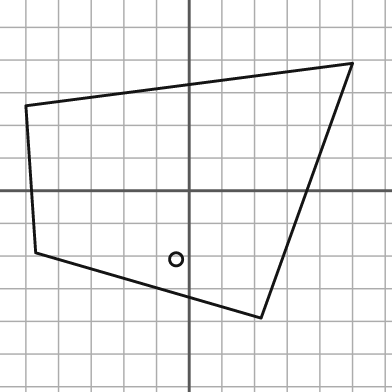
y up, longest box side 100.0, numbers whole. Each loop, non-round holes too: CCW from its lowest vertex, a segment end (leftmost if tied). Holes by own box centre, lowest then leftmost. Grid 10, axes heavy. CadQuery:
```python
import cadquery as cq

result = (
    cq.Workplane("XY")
    .moveTo(22.0, -39.0)
    .lineTo(50.0, 39.0)
    .lineTo(-50.0, 26.0)
    .lineTo(-47.0, -19.0)
    .close()
    .moveTo(-4.0, -21.0)
    .circle(2.0)
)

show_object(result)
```